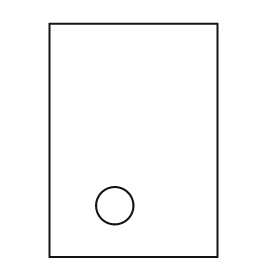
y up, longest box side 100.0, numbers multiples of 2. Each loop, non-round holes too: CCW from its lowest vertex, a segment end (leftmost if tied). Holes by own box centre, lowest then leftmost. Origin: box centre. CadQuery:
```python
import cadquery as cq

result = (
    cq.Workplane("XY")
    .moveTo(-36.0, -50.0)
    .lineTo(36.0, -50.0)
    .lineTo(36.0, 50.0)
    .lineTo(-36.0, 50.0)
    .close()
    .moveTo(-8.0, -28.0)
    .circle(8.0)
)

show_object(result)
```